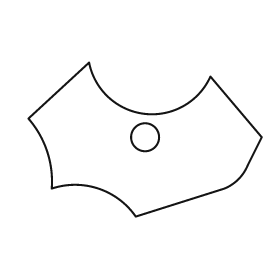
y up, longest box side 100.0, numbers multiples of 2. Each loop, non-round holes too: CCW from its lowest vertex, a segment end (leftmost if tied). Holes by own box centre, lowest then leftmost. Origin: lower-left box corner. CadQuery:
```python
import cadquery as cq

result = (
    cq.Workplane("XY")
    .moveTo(46.0, 0.0)
    .lineTo(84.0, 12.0)
    .threePointArc((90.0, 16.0), (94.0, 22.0))
    .lineTo(100.0, 34.0)
    .lineTo(78.0, 60.0)
    .threePointArc((50.0, 44.0), (26.0, 66.0))
    .lineTo(0.0, 42.0)
    .threePointArc((8.0, 28.0), (10.0, 12.0))
    .threePointArc((30.0, 12.0), (46.0, 0.0))
    .close()
    .moveTo(50.0, 34.0)
    .circle(6.0)
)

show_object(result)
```